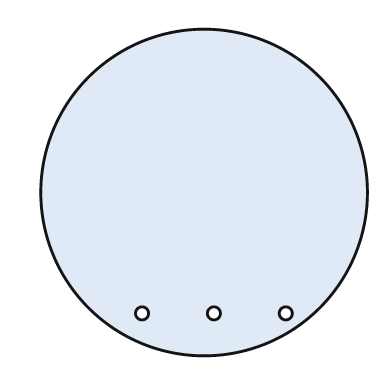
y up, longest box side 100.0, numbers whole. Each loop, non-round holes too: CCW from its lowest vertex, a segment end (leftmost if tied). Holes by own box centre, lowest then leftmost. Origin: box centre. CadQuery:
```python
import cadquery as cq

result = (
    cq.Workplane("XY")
    .moveTo(0.0, 0.0)
    .circle(50.0)
    .moveTo(-19.0, -37.0)
    .circle(2.0)
    .moveTo(3.0, -37.0)
    .circle(2.0)
    .moveTo(25.0, -37.0)
    .circle(2.0)
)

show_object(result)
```